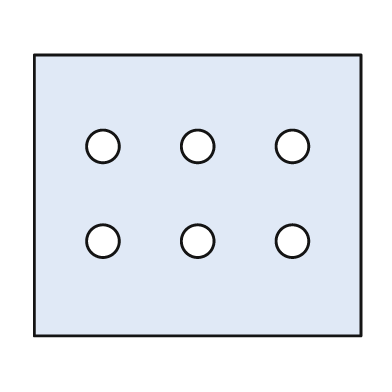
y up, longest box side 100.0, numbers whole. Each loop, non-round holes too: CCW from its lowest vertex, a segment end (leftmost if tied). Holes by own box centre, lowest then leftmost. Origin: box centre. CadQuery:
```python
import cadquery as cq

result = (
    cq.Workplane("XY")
    .moveTo(-50.0, -43.0)
    .lineTo(50.0, -43.0)
    .lineTo(50.0, 43.0)
    .lineTo(-50.0, 43.0)
    .close()
    .moveTo(-29.0, -14.0)
    .circle(5.0)
    .moveTo(0.0, -14.0)
    .circle(5.0)
    .moveTo(29.0, -14.0)
    .circle(5.0)
    .moveTo(-29.0, 15.0)
    .circle(5.0)
    .moveTo(0.0, 15.0)
    .circle(5.0)
    .moveTo(29.0, 15.0)
    .circle(5.0)
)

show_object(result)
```